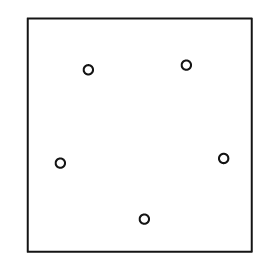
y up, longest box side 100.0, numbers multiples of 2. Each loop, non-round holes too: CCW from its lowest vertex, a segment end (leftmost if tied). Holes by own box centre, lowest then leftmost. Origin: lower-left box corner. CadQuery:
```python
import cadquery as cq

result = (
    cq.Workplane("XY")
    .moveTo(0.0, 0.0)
    .lineTo(96.0, 0.0)
    .lineTo(96.0, 100.0)
    .lineTo(0.0, 100.0)
    .close()
    .moveTo(50.0, 14.0)
    .circle(2.0)
    .moveTo(14.0, 38.0)
    .circle(2.0)
    .moveTo(84.0, 40.0)
    .circle(2.0)
    .moveTo(26.0, 78.0)
    .circle(2.0)
    .moveTo(68.0, 80.0)
    .circle(2.0)
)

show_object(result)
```